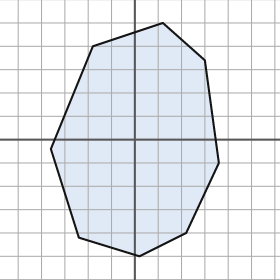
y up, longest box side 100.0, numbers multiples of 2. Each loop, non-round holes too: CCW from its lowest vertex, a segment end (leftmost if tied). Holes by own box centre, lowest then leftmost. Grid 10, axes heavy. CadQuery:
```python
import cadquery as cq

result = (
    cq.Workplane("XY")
    .moveTo(2.0, -50.0)
    .lineTo(22.0, -40.0)
    .lineTo(36.0, -10.0)
    .lineTo(30.0, 34.0)
    .lineTo(12.0, 50.0)
    .lineTo(-18.0, 40.0)
    .lineTo(-36.0, -4.0)
    .lineTo(-24.0, -42.0)
    .close()
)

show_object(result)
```